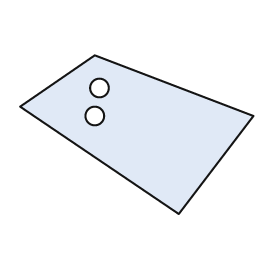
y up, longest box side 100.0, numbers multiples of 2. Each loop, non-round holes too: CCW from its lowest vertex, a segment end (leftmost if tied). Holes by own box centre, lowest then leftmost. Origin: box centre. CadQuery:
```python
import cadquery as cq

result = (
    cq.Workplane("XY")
    .moveTo(18.0, -34.0)
    .lineTo(50.0, 8.0)
    .lineTo(-18.0, 34.0)
    .lineTo(-50.0, 12.0)
    .close()
    .moveTo(-18.0, 8.0)
    .circle(4.0)
    .moveTo(-16.0, 20.0)
    .circle(4.0)
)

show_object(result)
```